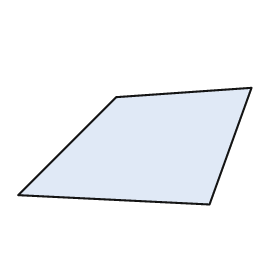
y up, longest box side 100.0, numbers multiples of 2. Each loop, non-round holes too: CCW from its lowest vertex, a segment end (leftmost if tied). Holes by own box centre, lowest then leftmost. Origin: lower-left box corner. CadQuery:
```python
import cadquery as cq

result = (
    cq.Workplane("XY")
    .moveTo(82.0, 0.0)
    .lineTo(100.0, 50.0)
    .lineTo(42.0, 46.0)
    .lineTo(0.0, 4.0)
    .close()
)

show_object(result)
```